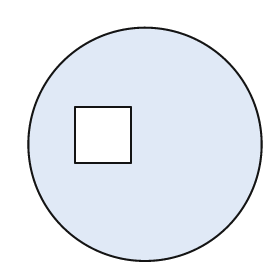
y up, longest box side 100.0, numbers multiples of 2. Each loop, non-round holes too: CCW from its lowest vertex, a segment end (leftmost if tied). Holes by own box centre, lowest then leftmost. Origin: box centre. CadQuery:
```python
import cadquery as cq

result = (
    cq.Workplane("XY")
    .moveTo(0.0, 0.0)
    .circle(50.0)
    .moveTo(-30.0, -8.0)
    .lineTo(-6.0, -8.0)
    .lineTo(-6.0, 16.0)
    .lineTo(-30.0, 16.0)
    .close()
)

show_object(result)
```